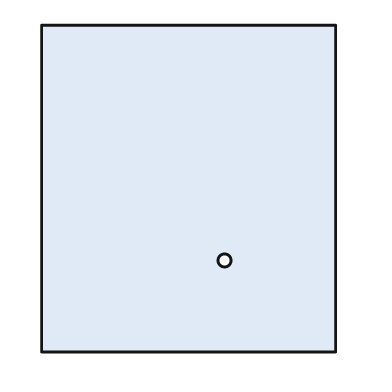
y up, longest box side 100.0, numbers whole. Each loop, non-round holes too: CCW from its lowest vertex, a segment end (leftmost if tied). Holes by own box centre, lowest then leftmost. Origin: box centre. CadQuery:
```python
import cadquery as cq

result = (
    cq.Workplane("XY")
    .moveTo(-45.0, -50.0)
    .lineTo(45.0, -50.0)
    .lineTo(45.0, 50.0)
    .lineTo(-45.0, 50.0)
    .close()
    .moveTo(11.0, -22.0)
    .circle(2.0)
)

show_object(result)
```